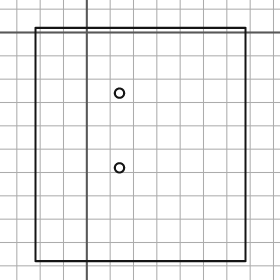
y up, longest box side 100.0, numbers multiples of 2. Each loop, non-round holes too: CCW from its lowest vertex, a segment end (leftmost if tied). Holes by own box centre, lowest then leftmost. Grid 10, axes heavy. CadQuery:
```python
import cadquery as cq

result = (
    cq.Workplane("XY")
    .moveTo(-22.0, -98.0)
    .lineTo(68.0, -98.0)
    .lineTo(68.0, 2.0)
    .lineTo(-22.0, 2.0)
    .close()
    .moveTo(14.0, -58.0)
    .circle(2.0)
    .moveTo(14.0, -26.0)
    .circle(2.0)
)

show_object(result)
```